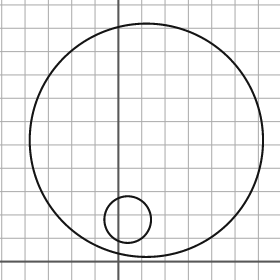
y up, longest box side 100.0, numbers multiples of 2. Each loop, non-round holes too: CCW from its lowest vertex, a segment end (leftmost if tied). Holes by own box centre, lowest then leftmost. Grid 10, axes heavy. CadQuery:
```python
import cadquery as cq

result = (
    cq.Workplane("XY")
    .moveTo(12.0, 52.0)
    .circle(50.0)
    .moveTo(4.0, 18.0)
    .circle(10.0)
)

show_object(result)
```